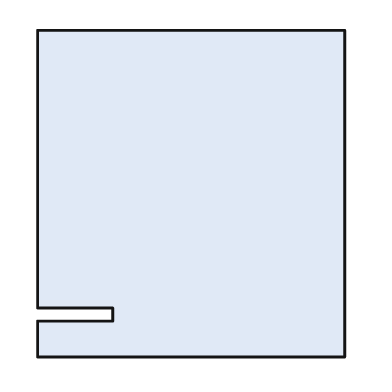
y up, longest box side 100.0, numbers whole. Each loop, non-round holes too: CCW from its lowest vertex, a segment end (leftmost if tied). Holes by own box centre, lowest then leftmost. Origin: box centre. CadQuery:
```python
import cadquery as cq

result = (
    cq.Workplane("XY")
    .moveTo(-47.0, -50.0)
    .lineTo(47.0, -50.0)
    .lineTo(47.0, 50.0)
    .lineTo(-47.0, 50.0)
    .lineTo(-47.0, -35.0)
    .lineTo(-24.0, -35.0)
    .lineTo(-24.0, -39.0)
    .lineTo(-47.0, -39.0)
    .close()
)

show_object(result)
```